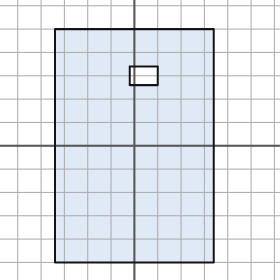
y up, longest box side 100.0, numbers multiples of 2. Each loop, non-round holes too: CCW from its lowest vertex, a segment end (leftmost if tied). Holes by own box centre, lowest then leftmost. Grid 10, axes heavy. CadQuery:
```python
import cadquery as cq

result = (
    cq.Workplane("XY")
    .moveTo(-34.0, -50.0)
    .lineTo(34.0, -50.0)
    .lineTo(34.0, 50.0)
    .lineTo(-34.0, 50.0)
    .close()
    .moveTo(-2.0, 26.0)
    .lineTo(10.0, 26.0)
    .lineTo(10.0, 34.0)
    .lineTo(-2.0, 34.0)
    .close()
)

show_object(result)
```